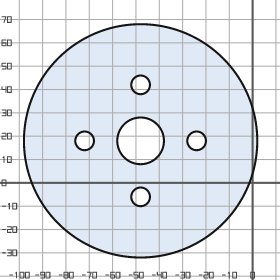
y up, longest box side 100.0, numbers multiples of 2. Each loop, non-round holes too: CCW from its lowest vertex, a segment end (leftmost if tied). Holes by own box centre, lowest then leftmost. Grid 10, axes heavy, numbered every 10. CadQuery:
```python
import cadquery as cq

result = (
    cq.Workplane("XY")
    .moveTo(-48.0, 18.0)
    .circle(50.0)
    .moveTo(-48.0, -6.0)
    .circle(4.0)
    .moveTo(-72.0, 18.0)
    .circle(4.0)
    .moveTo(-48.0, 18.0)
    .circle(10.0)
    .moveTo(-24.0, 18.0)
    .circle(4.0)
    .moveTo(-48.0, 42.0)
    .circle(4.0)
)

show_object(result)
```